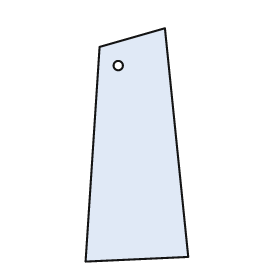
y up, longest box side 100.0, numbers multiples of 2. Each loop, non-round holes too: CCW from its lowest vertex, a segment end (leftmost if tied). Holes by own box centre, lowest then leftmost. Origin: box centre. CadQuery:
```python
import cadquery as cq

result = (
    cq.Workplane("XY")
    .moveTo(-22.0, -50.0)
    .lineTo(22.0, -48.0)
    .lineTo(12.0, 50.0)
    .lineTo(-16.0, 42.0)
    .close()
    .moveTo(-8.0, 34.0)
    .circle(2.0)
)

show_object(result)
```